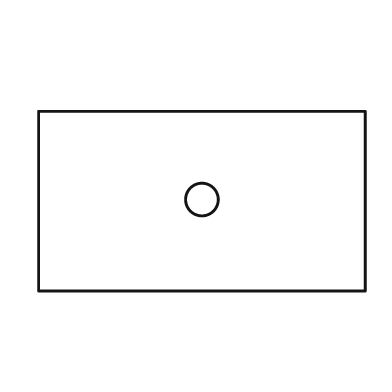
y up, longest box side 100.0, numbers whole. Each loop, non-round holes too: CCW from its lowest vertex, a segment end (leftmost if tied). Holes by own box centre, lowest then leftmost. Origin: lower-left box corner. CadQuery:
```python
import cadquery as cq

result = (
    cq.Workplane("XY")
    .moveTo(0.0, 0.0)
    .lineTo(100.0, 0.0)
    .lineTo(100.0, 55.0)
    .lineTo(0.0, 55.0)
    .close()
    .moveTo(50.0, 28.0)
    .circle(5.0)
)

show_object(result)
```